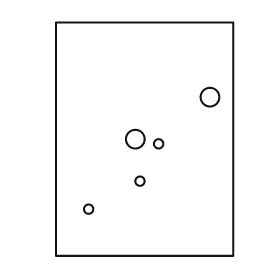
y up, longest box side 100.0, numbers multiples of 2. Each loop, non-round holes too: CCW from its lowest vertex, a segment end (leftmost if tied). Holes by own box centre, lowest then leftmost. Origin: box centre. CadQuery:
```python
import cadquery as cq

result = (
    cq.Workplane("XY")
    .moveTo(-38.0, -50.0)
    .lineTo(38.0, -50.0)
    .lineTo(38.0, 50.0)
    .lineTo(-38.0, 50.0)
    .close()
    .moveTo(-24.0, -30.0)
    .circle(2.0)
    .moveTo(-2.0, -18.0)
    .circle(2.0)
    .moveTo(6.0, -2.0)
    .circle(2.0)
    .moveTo(-4.0, 0.0)
    .circle(4.0)
    .moveTo(28.0, 18.0)
    .circle(4.0)
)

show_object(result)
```